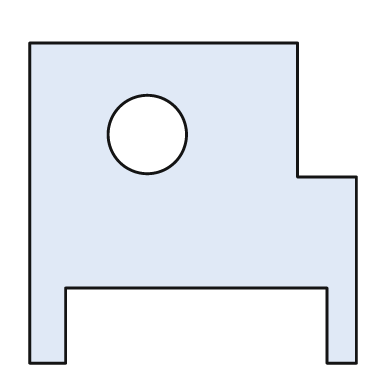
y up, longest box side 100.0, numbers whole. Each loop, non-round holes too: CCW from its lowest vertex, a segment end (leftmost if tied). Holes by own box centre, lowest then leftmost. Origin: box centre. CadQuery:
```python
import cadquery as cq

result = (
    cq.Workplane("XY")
    .moveTo(-50.0, -49.0)
    .lineTo(-39.0, -49.0)
    .lineTo(-39.0, -26.0)
    .lineTo(41.0, -26.0)
    .lineTo(41.0, -49.0)
    .lineTo(50.0, -49.0)
    .lineTo(50.0, 8.0)
    .lineTo(32.0, 8.0)
    .lineTo(32.0, 49.0)
    .lineTo(-50.0, 49.0)
    .close()
    .moveTo(-14.0, 21.0)
    .circle(12.0)
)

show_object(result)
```